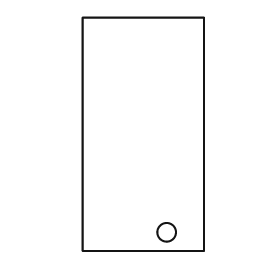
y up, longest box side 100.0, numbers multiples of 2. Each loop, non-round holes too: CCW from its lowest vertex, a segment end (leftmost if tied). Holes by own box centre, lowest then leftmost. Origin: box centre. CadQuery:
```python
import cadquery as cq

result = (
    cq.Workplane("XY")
    .moveTo(-26.0, -50.0)
    .lineTo(26.0, -50.0)
    .lineTo(26.0, 50.0)
    .lineTo(-26.0, 50.0)
    .close()
    .moveTo(10.0, -42.0)
    .circle(4.0)
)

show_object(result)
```